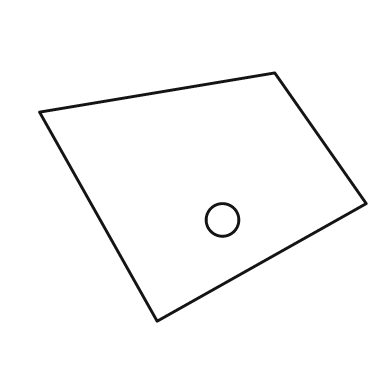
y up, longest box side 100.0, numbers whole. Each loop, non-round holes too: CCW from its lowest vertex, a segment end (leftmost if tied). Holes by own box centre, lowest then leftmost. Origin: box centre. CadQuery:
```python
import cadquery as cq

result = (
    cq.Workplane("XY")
    .moveTo(-14.0, -38.0)
    .lineTo(50.0, -2.0)
    .lineTo(22.0, 38.0)
    .lineTo(-50.0, 26.0)
    .close()
    .moveTo(6.0, -7.0)
    .circle(5.0)
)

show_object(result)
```